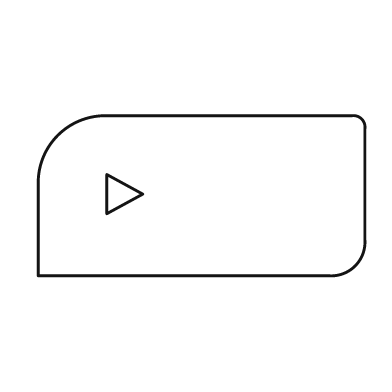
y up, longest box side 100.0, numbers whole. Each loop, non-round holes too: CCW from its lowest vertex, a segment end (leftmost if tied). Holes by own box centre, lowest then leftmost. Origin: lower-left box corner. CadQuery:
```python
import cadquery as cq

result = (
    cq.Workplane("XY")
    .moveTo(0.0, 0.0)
    .lineTo(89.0, 0.0)
    .threePointArc((97.0, 3.0), (100.0, 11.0))
    .lineTo(100.0, 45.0)
    .threePointArc((99.0, 48.0), (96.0, 49.0))
    .lineTo(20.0, 49.0)
    .threePointArc((6.0, 43.0), (0.0, 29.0))
    .close()
    .moveTo(21.0, 19.0)
    .lineTo(32.0, 25.0)
    .lineTo(21.0, 31.0)
    .close()
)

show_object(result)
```